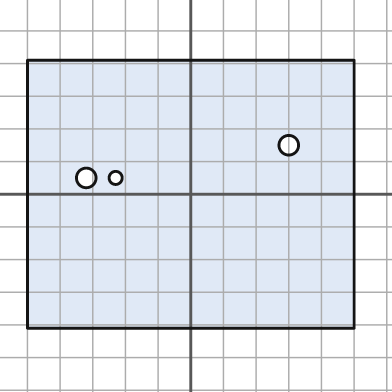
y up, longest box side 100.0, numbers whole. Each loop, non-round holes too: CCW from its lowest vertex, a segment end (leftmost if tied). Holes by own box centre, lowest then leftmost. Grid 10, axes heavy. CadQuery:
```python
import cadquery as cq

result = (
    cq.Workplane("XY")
    .moveTo(-50.0, -41.0)
    .lineTo(50.0, -41.0)
    .lineTo(50.0, 41.0)
    .lineTo(-50.0, 41.0)
    .close()
    .moveTo(-32.0, 5.0)
    .circle(3.0)
    .moveTo(-23.0, 5.0)
    .circle(2.0)
    .moveTo(30.0, 15.0)
    .circle(3.0)
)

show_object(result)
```